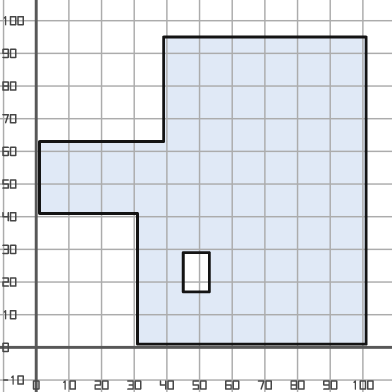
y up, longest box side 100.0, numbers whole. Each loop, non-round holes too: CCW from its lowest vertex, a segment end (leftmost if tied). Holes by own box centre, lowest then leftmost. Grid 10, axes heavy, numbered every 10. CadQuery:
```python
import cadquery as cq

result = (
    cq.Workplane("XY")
    .moveTo(31.0, 1.0)
    .lineTo(101.0, 1.0)
    .lineTo(101.0, 95.0)
    .lineTo(39.0, 95.0)
    .lineTo(39.0, 63.0)
    .lineTo(1.0, 63.0)
    .lineTo(1.0, 41.0)
    .lineTo(31.0, 41.0)
    .close()
    .moveTo(45.0, 17.0)
    .lineTo(53.0, 17.0)
    .lineTo(53.0, 29.0)
    .lineTo(45.0, 29.0)
    .close()
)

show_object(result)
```